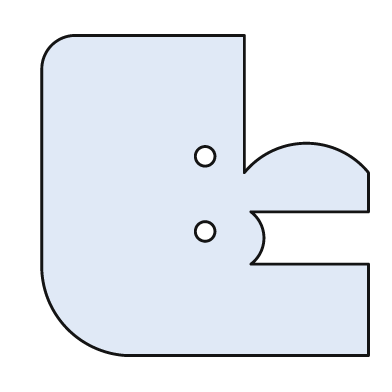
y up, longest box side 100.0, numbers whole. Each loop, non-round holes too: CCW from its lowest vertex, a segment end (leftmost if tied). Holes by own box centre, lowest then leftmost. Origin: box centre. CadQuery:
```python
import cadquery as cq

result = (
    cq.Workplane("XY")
    .moveTo(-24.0, -49.0)
    .lineTo(50.0, -49.0)
    .lineTo(50.0, -21.0)
    .lineTo(14.0, -21.0)
    .threePointArc((18.0, -13.0), (14.0, -5.0))
    .lineTo(50.0, -5.0)
    .lineTo(50.0, 7.0)
    .threePointArc((31.0, 16.0), (12.0, 7.0))
    .lineTo(12.0, 49.0)
    .lineTo(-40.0, 49.0)
    .threePointArc((-47.0, 46.0), (-50.0, 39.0))
    .lineTo(-50.0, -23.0)
    .threePointArc((-42.0, -41.0), (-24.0, -49.0))
    .close()
    .moveTo(0.0, -11.0)
    .circle(3.0)
    .moveTo(0.0, 12.0)
    .circle(3.0)
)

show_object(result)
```